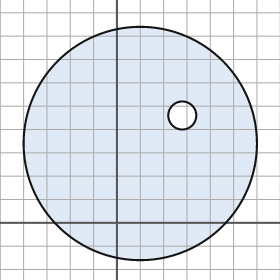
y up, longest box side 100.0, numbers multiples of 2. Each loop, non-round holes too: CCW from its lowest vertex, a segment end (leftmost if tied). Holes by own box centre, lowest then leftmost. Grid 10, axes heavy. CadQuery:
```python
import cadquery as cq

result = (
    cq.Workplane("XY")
    .moveTo(10.0, 34.0)
    .circle(50.0)
    .moveTo(28.0, 46.0)
    .circle(6.0)
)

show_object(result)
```